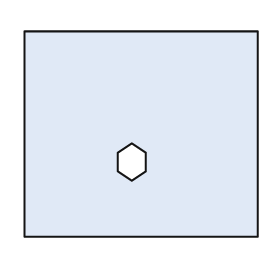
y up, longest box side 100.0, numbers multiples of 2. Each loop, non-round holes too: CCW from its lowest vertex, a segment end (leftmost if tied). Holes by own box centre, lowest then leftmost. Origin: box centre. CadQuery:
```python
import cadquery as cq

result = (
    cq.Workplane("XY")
    .moveTo(-50.0, -44.0)
    .lineTo(50.0, -44.0)
    .lineTo(50.0, 44.0)
    .lineTo(-50.0, 44.0)
    .close()
    .moveTo(-4.0, -20.0)
    .lineTo(2.0, -16.0)
    .lineTo(2.0, -8.0)
    .lineTo(-4.0, -4.0)
    .lineTo(-10.0, -8.0)
    .lineTo(-10.0, -16.0)
    .close()
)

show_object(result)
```